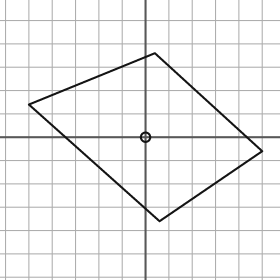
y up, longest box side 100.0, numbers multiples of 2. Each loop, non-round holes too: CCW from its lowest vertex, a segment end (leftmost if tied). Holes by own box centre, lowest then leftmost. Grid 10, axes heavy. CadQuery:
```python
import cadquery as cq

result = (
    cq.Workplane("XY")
    .moveTo(6.0, -36.0)
    .lineTo(50.0, -6.0)
    .lineTo(4.0, 36.0)
    .lineTo(-50.0, 14.0)
    .close()
    .moveTo(0.0, 0.0)
    .circle(2.0)
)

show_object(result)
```